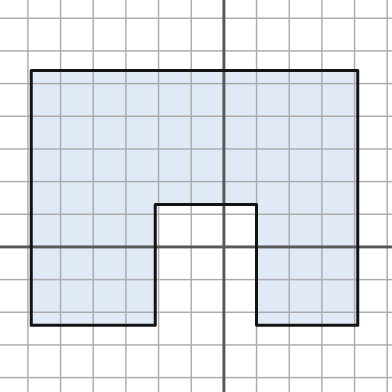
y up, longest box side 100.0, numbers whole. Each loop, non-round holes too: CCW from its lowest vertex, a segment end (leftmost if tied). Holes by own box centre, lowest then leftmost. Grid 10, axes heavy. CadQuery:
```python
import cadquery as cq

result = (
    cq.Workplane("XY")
    .moveTo(-59.0, -24.0)
    .lineTo(-21.0, -24.0)
    .lineTo(-21.0, 13.0)
    .lineTo(10.0, 13.0)
    .lineTo(10.0, -24.0)
    .lineTo(41.0, -24.0)
    .lineTo(41.0, 54.0)
    .lineTo(-59.0, 54.0)
    .close()
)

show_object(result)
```